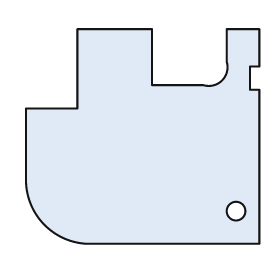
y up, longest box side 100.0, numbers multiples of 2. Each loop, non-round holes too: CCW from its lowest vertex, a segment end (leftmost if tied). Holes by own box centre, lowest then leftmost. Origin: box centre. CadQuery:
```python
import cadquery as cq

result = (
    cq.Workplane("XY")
    .moveTo(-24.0, -46.0)
    .lineTo(50.0, -46.0)
    .lineTo(50.0, 20.0)
    .lineTo(46.0, 20.0)
    .lineTo(46.0, 30.0)
    .lineTo(50.0, 30.0)
    .lineTo(50.0, 46.0)
    .lineTo(36.0, 46.0)
    .lineTo(36.0, 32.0)
    .threePointArc((34.0, 24.0), (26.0, 22.0))
    .lineTo(4.0, 22.0)
    .lineTo(4.0, 46.0)
    .lineTo(-28.0, 46.0)
    .lineTo(-28.0, 12.0)
    .lineTo(-50.0, 12.0)
    .lineTo(-50.0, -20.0)
    .threePointArc((-42.0, -38.0), (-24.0, -46.0))
    .close()
    .moveTo(40.0, -32.0)
    .circle(4.0)
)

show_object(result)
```